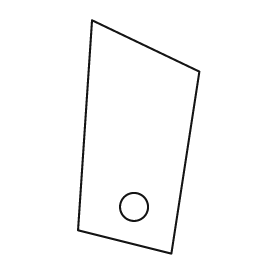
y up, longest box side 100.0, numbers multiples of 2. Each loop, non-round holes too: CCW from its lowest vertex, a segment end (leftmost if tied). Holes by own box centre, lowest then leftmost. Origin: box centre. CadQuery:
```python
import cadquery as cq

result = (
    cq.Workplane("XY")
    .moveTo(14.0, -50.0)
    .lineTo(26.0, 28.0)
    .lineTo(-20.0, 50.0)
    .lineTo(-26.0, -40.0)
    .close()
    .moveTo(-2.0, -30.0)
    .circle(6.0)
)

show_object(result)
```